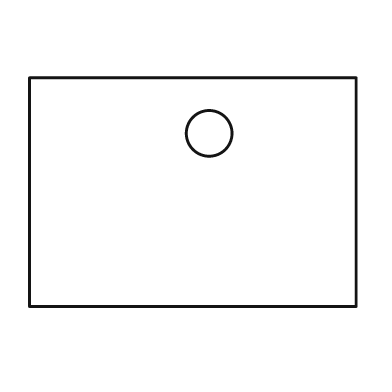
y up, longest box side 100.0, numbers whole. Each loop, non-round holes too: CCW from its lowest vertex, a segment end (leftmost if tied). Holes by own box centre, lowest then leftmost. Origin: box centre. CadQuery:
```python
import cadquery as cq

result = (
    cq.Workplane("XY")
    .moveTo(-50.0, -35.0)
    .lineTo(50.0, -35.0)
    .lineTo(50.0, 35.0)
    .lineTo(-50.0, 35.0)
    .close()
    .moveTo(5.0, 18.0)
    .circle(7.0)
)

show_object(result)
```